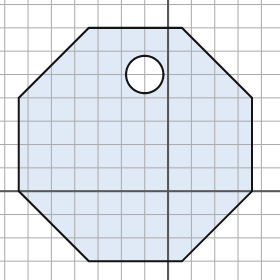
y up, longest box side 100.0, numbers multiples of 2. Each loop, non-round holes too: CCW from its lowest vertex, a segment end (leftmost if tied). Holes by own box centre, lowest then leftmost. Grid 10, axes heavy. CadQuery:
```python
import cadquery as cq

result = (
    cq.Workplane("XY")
    .moveTo(-34.0, -30.0)
    .lineTo(6.0, -30.0)
    .lineTo(36.0, 0.0)
    .lineTo(36.0, 40.0)
    .lineTo(6.0, 70.0)
    .lineTo(-34.0, 70.0)
    .lineTo(-64.0, 40.0)
    .lineTo(-64.0, 0.0)
    .close()
    .moveTo(-10.0, 50.0)
    .circle(8.0)
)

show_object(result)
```